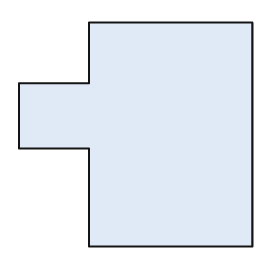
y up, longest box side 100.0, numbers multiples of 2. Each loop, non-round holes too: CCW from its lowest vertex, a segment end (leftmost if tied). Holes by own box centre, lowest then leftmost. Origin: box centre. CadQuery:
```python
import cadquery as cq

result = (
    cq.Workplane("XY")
    .moveTo(-20.0, -48.0)
    .lineTo(50.0, -48.0)
    .lineTo(50.0, 48.0)
    .lineTo(-20.0, 48.0)
    .lineTo(-20.0, 22.0)
    .lineTo(-50.0, 22.0)
    .lineTo(-50.0, -6.0)
    .lineTo(-20.0, -6.0)
    .close()
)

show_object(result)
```